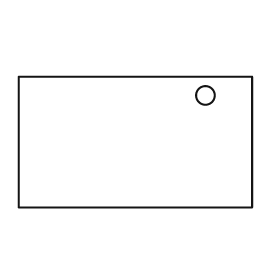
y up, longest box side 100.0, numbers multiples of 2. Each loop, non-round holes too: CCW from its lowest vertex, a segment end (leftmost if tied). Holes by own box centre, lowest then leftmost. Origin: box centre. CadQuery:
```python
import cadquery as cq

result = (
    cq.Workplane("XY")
    .moveTo(-50.0, -28.0)
    .lineTo(50.0, -28.0)
    .lineTo(50.0, 28.0)
    .lineTo(-50.0, 28.0)
    .close()
    .moveTo(30.0, 20.0)
    .circle(4.0)
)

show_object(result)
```